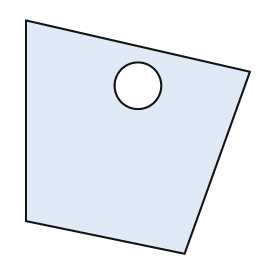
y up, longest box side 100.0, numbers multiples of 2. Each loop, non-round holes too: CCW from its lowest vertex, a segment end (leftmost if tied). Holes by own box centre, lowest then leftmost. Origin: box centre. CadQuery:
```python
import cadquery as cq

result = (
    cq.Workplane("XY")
    .moveTo(20.0, -50.0)
    .lineTo(48.0, 28.0)
    .lineTo(-48.0, 50.0)
    .lineTo(-48.0, -36.0)
    .close()
    .moveTo(0.0, 22.0)
    .circle(10.0)
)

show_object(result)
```